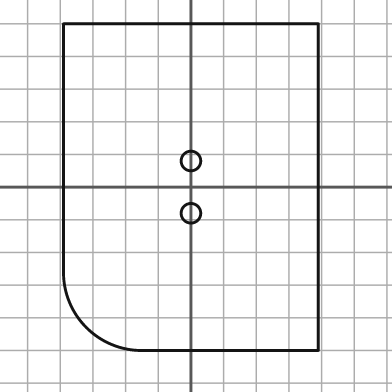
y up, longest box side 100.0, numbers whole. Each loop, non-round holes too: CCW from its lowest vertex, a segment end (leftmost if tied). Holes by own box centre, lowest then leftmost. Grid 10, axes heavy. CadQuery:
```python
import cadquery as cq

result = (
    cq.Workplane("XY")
    .moveTo(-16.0, -50.0)
    .lineTo(39.0, -50.0)
    .lineTo(39.0, 50.0)
    .lineTo(-39.0, 50.0)
    .lineTo(-39.0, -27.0)
    .threePointArc((-32.0, -43.0), (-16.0, -50.0))
    .close()
    .moveTo(0.0, -8.0)
    .circle(3.0)
    .moveTo(0.0, 8.0)
    .circle(3.0)
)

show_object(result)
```